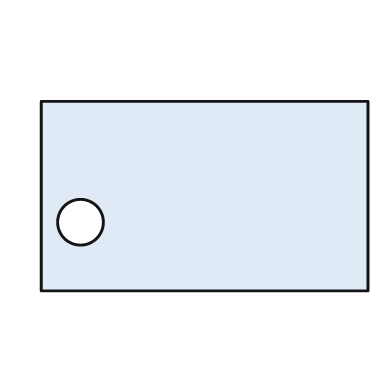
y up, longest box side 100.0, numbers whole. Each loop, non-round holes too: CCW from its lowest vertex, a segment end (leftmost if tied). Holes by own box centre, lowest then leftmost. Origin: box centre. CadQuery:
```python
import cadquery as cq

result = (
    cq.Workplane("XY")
    .moveTo(-50.0, -29.0)
    .lineTo(50.0, -29.0)
    .lineTo(50.0, 29.0)
    .lineTo(-50.0, 29.0)
    .close()
    .moveTo(-38.0, -8.0)
    .circle(7.0)
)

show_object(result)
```